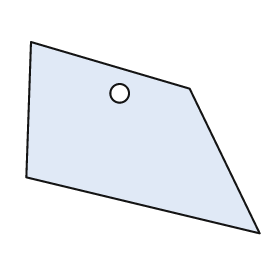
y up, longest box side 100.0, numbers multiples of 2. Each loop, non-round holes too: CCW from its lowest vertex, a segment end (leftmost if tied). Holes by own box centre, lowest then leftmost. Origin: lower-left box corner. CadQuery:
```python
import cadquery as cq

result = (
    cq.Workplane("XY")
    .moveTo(100.0, 0.0)
    .lineTo(70.0, 62.0)
    .lineTo(2.0, 82.0)
    .lineTo(0.0, 24.0)
    .close()
    .moveTo(40.0, 60.0)
    .circle(4.0)
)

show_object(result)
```